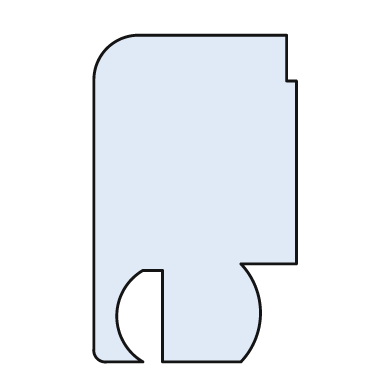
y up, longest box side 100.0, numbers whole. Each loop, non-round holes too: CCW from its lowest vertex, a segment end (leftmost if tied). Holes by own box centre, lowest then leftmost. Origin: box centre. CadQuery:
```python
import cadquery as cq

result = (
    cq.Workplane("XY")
    .moveTo(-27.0, -50.0)
    .lineTo(-16.0, -50.0)
    .threePointArc((-24.0, -36.0), (-16.0, -22.0))
    .lineTo(-10.0, -22.0)
    .lineTo(-10.0, -50.0)
    .lineTo(14.0, -50.0)
    .threePointArc((20.0, -35.0), (14.0, -20.0))
    .lineTo(31.0, -20.0)
    .lineTo(31.0, 36.0)
    .lineTo(28.0, 36.0)
    .lineTo(28.0, 50.0)
    .lineTo(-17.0, 50.0)
    .threePointArc((-27.0, 46.0), (-31.0, 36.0))
    .lineTo(-31.0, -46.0)
    .threePointArc((-30.0, -49.0), (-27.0, -50.0))
    .close()
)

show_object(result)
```